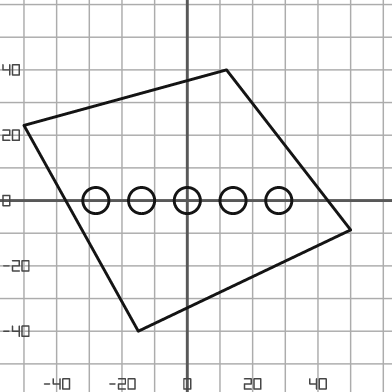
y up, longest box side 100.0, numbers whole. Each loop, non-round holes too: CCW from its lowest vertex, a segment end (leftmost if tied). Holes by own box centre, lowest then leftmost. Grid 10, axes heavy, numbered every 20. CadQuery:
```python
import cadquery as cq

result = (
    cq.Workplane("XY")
    .moveTo(-15.0, -40.0)
    .lineTo(50.0, -9.0)
    .lineTo(12.0, 40.0)
    .lineTo(-50.0, 23.0)
    .close()
    .moveTo(-28.0, 0.0)
    .circle(4.0)
    .moveTo(-14.0, 0.0)
    .circle(4.0)
    .moveTo(0.0, 0.0)
    .circle(4.0)
    .moveTo(14.0, 0.0)
    .circle(4.0)
    .moveTo(28.0, 0.0)
    .circle(4.0)
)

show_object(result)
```